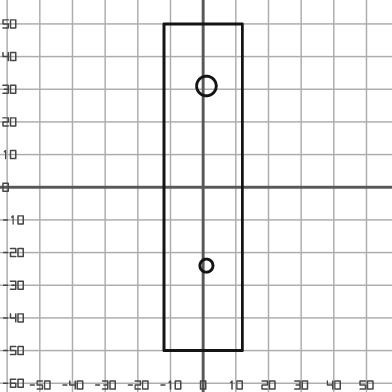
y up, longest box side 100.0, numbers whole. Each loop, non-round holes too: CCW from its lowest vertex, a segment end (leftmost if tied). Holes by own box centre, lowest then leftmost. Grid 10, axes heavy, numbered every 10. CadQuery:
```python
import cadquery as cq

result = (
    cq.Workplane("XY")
    .moveTo(-12.0, -50.0)
    .lineTo(12.0, -50.0)
    .lineTo(12.0, 50.0)
    .lineTo(-12.0, 50.0)
    .close()
    .moveTo(1.0, -24.0)
    .circle(2.0)
    .moveTo(1.0, 31.0)
    .circle(3.0)
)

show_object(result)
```